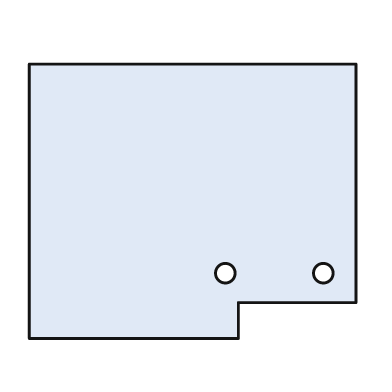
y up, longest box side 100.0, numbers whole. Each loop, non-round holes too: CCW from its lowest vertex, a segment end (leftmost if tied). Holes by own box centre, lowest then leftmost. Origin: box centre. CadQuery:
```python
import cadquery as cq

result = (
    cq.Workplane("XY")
    .moveTo(-50.0, -42.0)
    .lineTo(14.0, -42.0)
    .lineTo(14.0, -31.0)
    .lineTo(50.0, -31.0)
    .lineTo(50.0, 42.0)
    .lineTo(-50.0, 42.0)
    .close()
    .moveTo(10.0, -22.0)
    .circle(3.0)
    .moveTo(40.0, -22.0)
    .circle(3.0)
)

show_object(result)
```